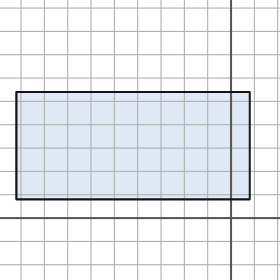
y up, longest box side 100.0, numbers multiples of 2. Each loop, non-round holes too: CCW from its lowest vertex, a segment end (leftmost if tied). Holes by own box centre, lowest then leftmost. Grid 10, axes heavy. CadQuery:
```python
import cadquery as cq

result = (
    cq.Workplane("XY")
    .moveTo(-92.0, 8.0)
    .lineTo(8.0, 8.0)
    .lineTo(8.0, 54.0)
    .lineTo(-92.0, 54.0)
    .close()
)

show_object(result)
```